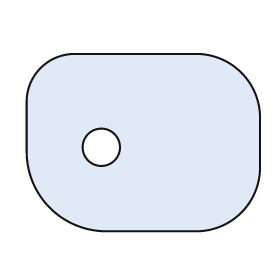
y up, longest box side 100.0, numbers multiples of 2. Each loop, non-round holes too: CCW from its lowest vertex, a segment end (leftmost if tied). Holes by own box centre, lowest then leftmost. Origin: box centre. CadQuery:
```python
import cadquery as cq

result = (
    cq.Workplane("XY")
    .moveTo(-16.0, -38.0)
    .lineTo(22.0, -38.0)
    .threePointArc((42.0, -30.0), (50.0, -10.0))
    .lineTo(50.0, 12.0)
    .threePointArc((42.0, 30.0), (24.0, 38.0))
    .lineTo(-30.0, 38.0)
    .threePointArc((-44.0, 32.0), (-50.0, 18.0))
    .lineTo(-50.0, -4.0)
    .threePointArc((-40.0, -28.0), (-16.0, -38.0))
    .close()
    .moveTo(-18.0, -2.0)
    .circle(8.0)
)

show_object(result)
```